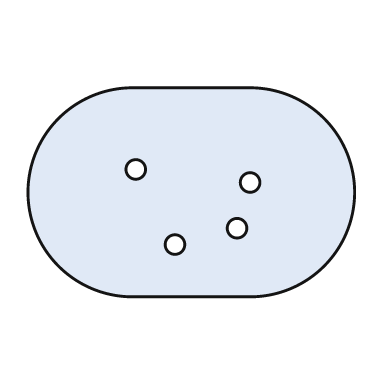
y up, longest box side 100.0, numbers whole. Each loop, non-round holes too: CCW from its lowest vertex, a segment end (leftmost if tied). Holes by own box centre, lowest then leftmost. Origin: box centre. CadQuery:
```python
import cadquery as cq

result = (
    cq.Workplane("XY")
    .moveTo(-18.0, -32.0)
    .lineTo(18.0, -32.0)
    .threePointArc((50.0, 0.0), (18.0, 32.0))
    .lineTo(-18.0, 32.0)
    .threePointArc((-50.0, 0.0), (-18.0, -32.0))
    .close()
    .moveTo(-5.0, -16.0)
    .circle(3.0)
    .moveTo(14.0, -11.0)
    .circle(3.0)
    .moveTo(18.0, 3.0)
    .circle(3.0)
    .moveTo(-17.0, 7.0)
    .circle(3.0)
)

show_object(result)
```